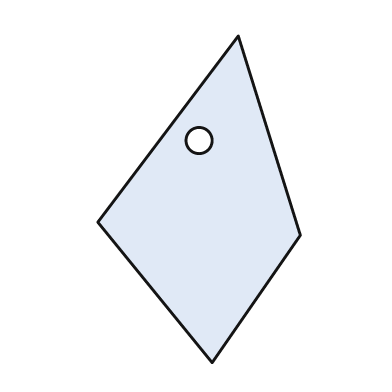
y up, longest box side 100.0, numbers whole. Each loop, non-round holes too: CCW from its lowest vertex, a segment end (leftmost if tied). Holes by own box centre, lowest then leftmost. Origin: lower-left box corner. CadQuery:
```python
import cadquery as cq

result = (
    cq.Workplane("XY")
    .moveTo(35.0, 0.0)
    .lineTo(62.0, 39.0)
    .lineTo(43.0, 100.0)
    .lineTo(0.0, 43.0)
    .close()
    .moveTo(31.0, 68.0)
    .circle(4.0)
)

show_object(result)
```